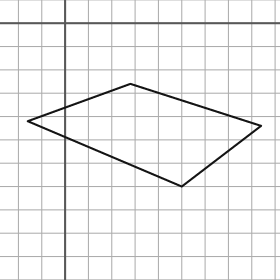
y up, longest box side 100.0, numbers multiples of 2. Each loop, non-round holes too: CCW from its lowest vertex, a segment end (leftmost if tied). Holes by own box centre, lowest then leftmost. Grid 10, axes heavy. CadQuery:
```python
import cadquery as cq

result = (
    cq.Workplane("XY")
    .moveTo(50.0, -70.0)
    .lineTo(84.0, -44.0)
    .lineTo(28.0, -26.0)
    .lineTo(-16.0, -42.0)
    .close()
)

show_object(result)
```